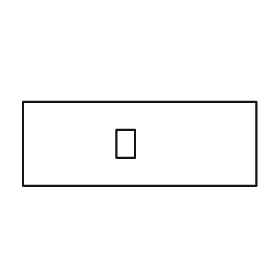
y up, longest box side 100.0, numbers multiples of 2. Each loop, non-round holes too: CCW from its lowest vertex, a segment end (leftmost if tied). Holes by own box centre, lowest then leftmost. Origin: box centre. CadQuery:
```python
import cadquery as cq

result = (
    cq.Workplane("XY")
    .moveTo(-50.0, -18.0)
    .lineTo(50.0, -18.0)
    .lineTo(50.0, 18.0)
    .lineTo(-50.0, 18.0)
    .close()
    .moveTo(-10.0, -6.0)
    .lineTo(-2.0, -6.0)
    .lineTo(-2.0, 6.0)
    .lineTo(-10.0, 6.0)
    .close()
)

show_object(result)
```